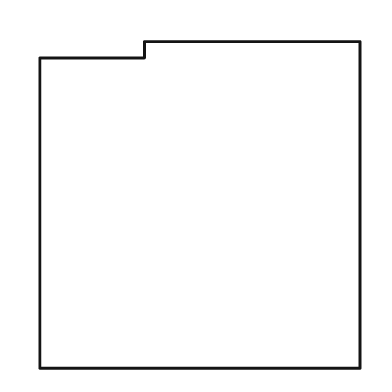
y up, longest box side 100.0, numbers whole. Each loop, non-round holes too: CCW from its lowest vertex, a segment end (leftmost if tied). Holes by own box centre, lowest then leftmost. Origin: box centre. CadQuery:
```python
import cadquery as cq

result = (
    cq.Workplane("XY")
    .moveTo(-49.0, -50.0)
    .lineTo(49.0, -50.0)
    .lineTo(49.0, 50.0)
    .lineTo(-17.0, 50.0)
    .lineTo(-17.0, 45.0)
    .lineTo(-49.0, 45.0)
    .close()
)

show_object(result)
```